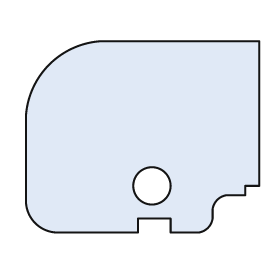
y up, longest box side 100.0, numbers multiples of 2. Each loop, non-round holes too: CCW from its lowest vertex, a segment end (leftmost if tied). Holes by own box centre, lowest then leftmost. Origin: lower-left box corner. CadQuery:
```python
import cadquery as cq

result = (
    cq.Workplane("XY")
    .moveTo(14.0, 0.0)
    .lineTo(48.0, 0.0)
    .lineTo(48.0, 6.0)
    .lineTo(62.0, 6.0)
    .lineTo(62.0, 0.0)
    .lineTo(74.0, 0.0)
    .threePointArc((78.0, 2.0), (80.0, 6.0))
    .lineTo(80.0, 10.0)
    .threePointArc((82.0, 14.0), (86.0, 16.0))
    .lineTo(94.0, 16.0)
    .lineTo(94.0, 20.0)
    .lineTo(100.0, 20.0)
    .lineTo(100.0, 82.0)
    .lineTo(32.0, 82.0)
    .threePointArc((10.0, 72.0), (0.0, 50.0))
    .lineTo(0.0, 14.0)
    .threePointArc((4.0, 4.0), (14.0, 0.0))
    .close()
    .moveTo(54.0, 20.0)
    .circle(8.0)
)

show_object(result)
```